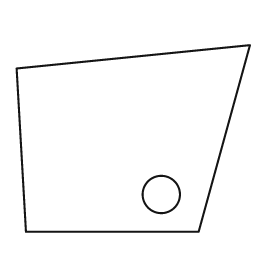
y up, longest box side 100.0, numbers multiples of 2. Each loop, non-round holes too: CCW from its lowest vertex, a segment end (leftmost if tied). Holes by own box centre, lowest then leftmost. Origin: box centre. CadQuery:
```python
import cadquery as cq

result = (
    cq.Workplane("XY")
    .moveTo(-46.0, -40.0)
    .lineTo(28.0, -40.0)
    .lineTo(50.0, 40.0)
    .lineTo(-50.0, 30.0)
    .close()
    .moveTo(12.0, -24.0)
    .circle(8.0)
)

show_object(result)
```